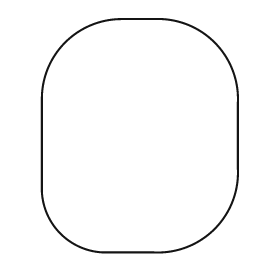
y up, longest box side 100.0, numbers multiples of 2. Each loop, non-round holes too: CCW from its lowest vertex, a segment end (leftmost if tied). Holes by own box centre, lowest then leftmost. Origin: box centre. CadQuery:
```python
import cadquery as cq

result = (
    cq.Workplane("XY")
    .moveTo(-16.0, -50.0)
    .lineTo(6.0, -50.0)
    .threePointArc((32.0, -40.0), (42.0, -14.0))
    .lineTo(42.0, 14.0)
    .threePointArc((32.0, 40.0), (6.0, 50.0))
    .lineTo(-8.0, 50.0)
    .threePointArc((-32.0, 40.0), (-42.0, 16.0))
    .lineTo(-42.0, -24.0)
    .threePointArc((-34.0, -42.0), (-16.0, -50.0))
    .close()
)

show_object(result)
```